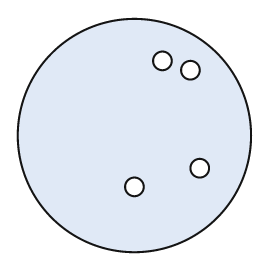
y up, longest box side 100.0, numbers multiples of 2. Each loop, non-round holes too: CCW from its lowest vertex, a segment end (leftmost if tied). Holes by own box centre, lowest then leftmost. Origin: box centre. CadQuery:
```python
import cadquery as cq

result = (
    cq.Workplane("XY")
    .moveTo(0.0, 0.0)
    .circle(50.0)
    .moveTo(0.0, -22.0)
    .circle(4.0)
    .moveTo(28.0, -14.0)
    .circle(4.0)
    .moveTo(24.0, 28.0)
    .circle(4.0)
    .moveTo(12.0, 32.0)
    .circle(4.0)
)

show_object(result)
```